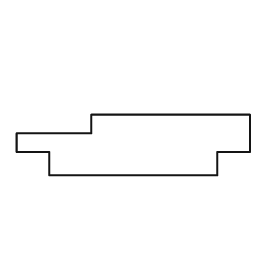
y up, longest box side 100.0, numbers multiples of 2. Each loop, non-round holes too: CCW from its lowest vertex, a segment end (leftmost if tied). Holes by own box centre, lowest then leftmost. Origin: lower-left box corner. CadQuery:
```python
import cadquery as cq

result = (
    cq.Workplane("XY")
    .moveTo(14.0, 0.0)
    .lineTo(86.0, 0.0)
    .lineTo(86.0, 10.0)
    .lineTo(100.0, 10.0)
    .lineTo(100.0, 26.0)
    .lineTo(32.0, 26.0)
    .lineTo(32.0, 18.0)
    .lineTo(0.0, 18.0)
    .lineTo(0.0, 10.0)
    .lineTo(14.0, 10.0)
    .close()
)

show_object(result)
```